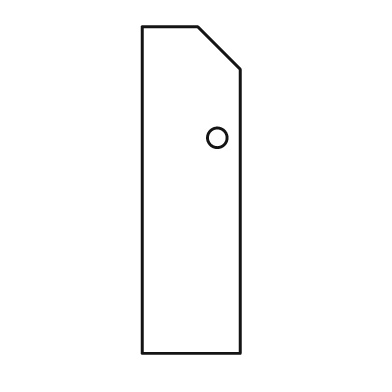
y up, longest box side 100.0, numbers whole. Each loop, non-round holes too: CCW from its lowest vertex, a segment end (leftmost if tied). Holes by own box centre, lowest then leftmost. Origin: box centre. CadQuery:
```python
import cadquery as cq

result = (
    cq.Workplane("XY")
    .moveTo(-15.0, -50.0)
    .lineTo(15.0, -50.0)
    .lineTo(15.0, 37.0)
    .lineTo(2.0, 50.0)
    .lineTo(-15.0, 50.0)
    .close()
    .moveTo(8.0, 16.0)
    .circle(3.0)
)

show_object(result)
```